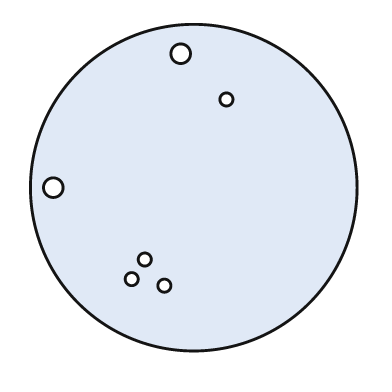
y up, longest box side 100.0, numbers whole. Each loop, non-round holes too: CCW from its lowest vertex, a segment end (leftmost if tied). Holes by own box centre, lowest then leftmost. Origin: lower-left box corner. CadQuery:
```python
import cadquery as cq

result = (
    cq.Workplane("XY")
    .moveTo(50.0, 50.0)
    .circle(50.0)
    .moveTo(41.0, 20.0)
    .circle(2.0)
    .moveTo(31.0, 22.0)
    .circle(2.0)
    .moveTo(35.0, 28.0)
    .circle(2.0)
    .moveTo(7.0, 50.0)
    .circle(3.0)
    .moveTo(60.0, 77.0)
    .circle(2.0)
    .moveTo(46.0, 91.0)
    .circle(3.0)
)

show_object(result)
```